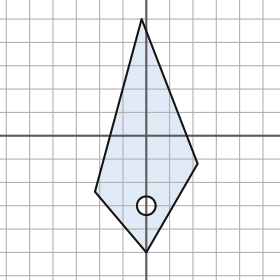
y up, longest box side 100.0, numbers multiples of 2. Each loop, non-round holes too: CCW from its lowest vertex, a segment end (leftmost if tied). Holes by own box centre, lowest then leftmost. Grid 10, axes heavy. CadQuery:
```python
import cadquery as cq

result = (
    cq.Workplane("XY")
    .moveTo(0.0, -50.0)
    .lineTo(22.0, -12.0)
    .lineTo(-2.0, 50.0)
    .lineTo(-22.0, -24.0)
    .close()
    .moveTo(0.0, -30.0)
    .circle(4.0)
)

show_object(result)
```